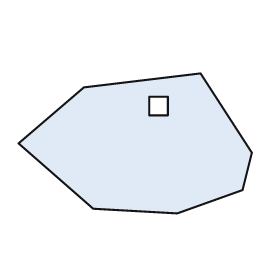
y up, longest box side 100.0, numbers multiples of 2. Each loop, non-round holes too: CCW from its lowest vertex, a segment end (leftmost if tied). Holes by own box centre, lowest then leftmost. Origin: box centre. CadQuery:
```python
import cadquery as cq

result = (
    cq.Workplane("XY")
    .moveTo(18.0, -30.0)
    .lineTo(46.0, -20.0)
    .lineTo(50.0, -4.0)
    .lineTo(28.0, 30.0)
    .lineTo(-22.0, 24.0)
    .lineTo(-50.0, 0.0)
    .lineTo(-18.0, -28.0)
    .close()
    .moveTo(6.0, 12.0)
    .lineTo(14.0, 12.0)
    .lineTo(14.0, 20.0)
    .lineTo(6.0, 20.0)
    .close()
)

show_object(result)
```